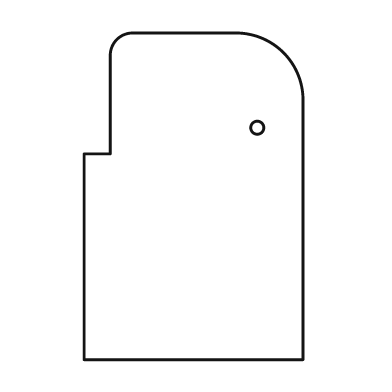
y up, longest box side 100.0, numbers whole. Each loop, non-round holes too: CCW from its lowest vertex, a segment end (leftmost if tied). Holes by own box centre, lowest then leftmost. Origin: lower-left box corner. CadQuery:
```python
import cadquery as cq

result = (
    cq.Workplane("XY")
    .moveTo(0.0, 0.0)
    .lineTo(67.0, 0.0)
    .lineTo(67.0, 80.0)
    .threePointArc((61.0, 94.0), (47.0, 100.0))
    .lineTo(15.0, 100.0)
    .threePointArc((10.0, 98.0), (8.0, 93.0))
    .lineTo(8.0, 63.0)
    .lineTo(0.0, 63.0)
    .close()
    .moveTo(53.0, 71.0)
    .circle(2.0)
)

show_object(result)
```